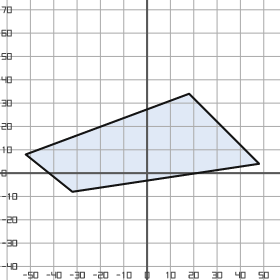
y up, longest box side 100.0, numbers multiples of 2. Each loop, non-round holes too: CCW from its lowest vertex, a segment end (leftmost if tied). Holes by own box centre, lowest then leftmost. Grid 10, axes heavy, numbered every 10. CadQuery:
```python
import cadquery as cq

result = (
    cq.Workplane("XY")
    .moveTo(-32.0, -8.0)
    .lineTo(48.0, 4.0)
    .lineTo(18.0, 34.0)
    .lineTo(-52.0, 8.0)
    .close()
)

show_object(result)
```